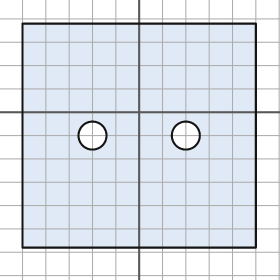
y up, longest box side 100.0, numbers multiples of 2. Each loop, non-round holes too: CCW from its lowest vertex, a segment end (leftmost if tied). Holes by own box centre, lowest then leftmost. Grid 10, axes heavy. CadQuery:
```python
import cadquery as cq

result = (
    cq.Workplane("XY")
    .moveTo(-50.0, -58.0)
    .lineTo(50.0, -58.0)
    .lineTo(50.0, 38.0)
    .lineTo(-50.0, 38.0)
    .close()
    .moveTo(-20.0, -10.0)
    .circle(6.0)
    .moveTo(20.0, -10.0)
    .circle(6.0)
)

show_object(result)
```